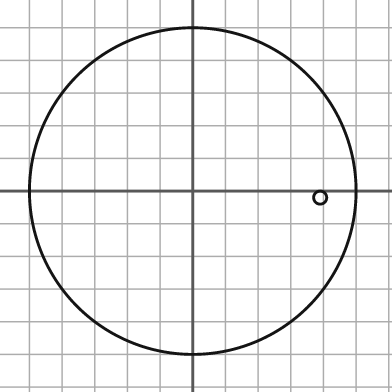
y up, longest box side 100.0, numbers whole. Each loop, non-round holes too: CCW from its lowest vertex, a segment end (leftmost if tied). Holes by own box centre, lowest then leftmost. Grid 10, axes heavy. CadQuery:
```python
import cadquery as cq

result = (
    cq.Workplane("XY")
    .moveTo(0.0, 0.0)
    .circle(50.0)
    .moveTo(39.0, -2.0)
    .circle(2.0)
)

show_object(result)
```